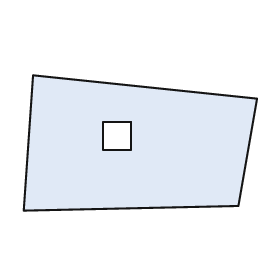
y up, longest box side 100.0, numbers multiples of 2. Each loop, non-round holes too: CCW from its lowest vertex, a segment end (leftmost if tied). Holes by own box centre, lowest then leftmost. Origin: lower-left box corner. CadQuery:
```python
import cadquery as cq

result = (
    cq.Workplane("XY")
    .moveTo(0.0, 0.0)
    .lineTo(92.0, 2.0)
    .lineTo(100.0, 48.0)
    .lineTo(4.0, 58.0)
    .close()
    .moveTo(34.0, 26.0)
    .lineTo(46.0, 26.0)
    .lineTo(46.0, 38.0)
    .lineTo(34.0, 38.0)
    .close()
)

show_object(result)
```